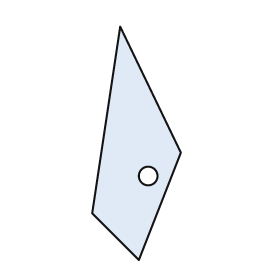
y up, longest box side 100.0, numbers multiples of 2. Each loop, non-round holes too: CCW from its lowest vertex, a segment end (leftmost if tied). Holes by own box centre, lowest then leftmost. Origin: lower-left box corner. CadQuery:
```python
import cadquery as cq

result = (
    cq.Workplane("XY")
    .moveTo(20.0, 0.0)
    .lineTo(38.0, 46.0)
    .lineTo(12.0, 100.0)
    .lineTo(0.0, 20.0)
    .close()
    .moveTo(24.0, 36.0)
    .circle(4.0)
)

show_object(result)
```